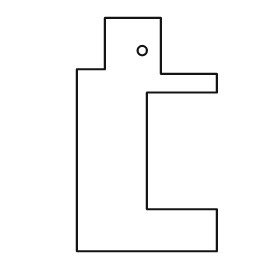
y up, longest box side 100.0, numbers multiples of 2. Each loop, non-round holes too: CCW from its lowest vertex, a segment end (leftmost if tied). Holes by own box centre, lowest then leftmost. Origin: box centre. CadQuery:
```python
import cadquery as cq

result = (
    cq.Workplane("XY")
    .moveTo(-30.0, -50.0)
    .lineTo(30.0, -50.0)
    .lineTo(30.0, -32.0)
    .lineTo(0.0, -32.0)
    .lineTo(0.0, 18.0)
    .lineTo(30.0, 18.0)
    .lineTo(30.0, 26.0)
    .lineTo(6.0, 26.0)
    .lineTo(6.0, 50.0)
    .lineTo(-18.0, 50.0)
    .lineTo(-18.0, 28.0)
    .lineTo(-30.0, 28.0)
    .close()
    .moveTo(-2.0, 36.0)
    .circle(2.0)
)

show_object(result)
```